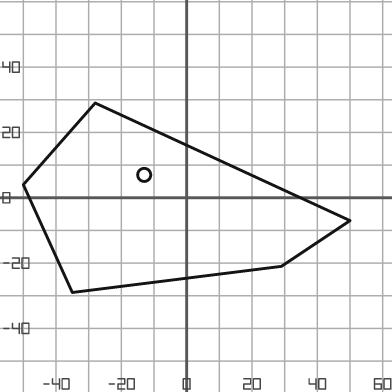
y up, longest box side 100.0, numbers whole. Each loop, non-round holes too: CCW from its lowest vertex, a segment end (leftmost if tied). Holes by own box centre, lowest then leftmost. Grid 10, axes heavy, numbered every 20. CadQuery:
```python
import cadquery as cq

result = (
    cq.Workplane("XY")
    .moveTo(-35.0, -29.0)
    .lineTo(29.0, -21.0)
    .lineTo(50.0, -7.0)
    .lineTo(-28.0, 29.0)
    .lineTo(-50.0, 4.0)
    .close()
    .moveTo(-13.0, 7.0)
    .circle(2.0)
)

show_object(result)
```